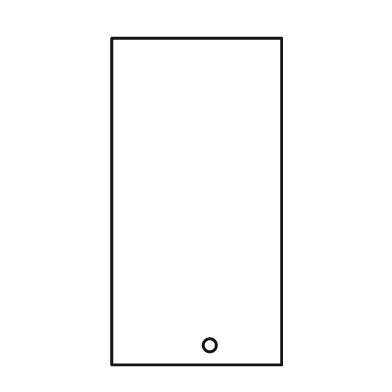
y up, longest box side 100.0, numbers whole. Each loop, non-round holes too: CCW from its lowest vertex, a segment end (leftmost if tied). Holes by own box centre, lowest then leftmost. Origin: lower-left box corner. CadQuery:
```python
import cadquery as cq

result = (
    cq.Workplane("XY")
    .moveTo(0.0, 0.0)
    .lineTo(52.0, 0.0)
    .lineTo(52.0, 100.0)
    .lineTo(0.0, 100.0)
    .close()
    .moveTo(30.0, 6.0)
    .circle(2.0)
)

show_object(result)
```